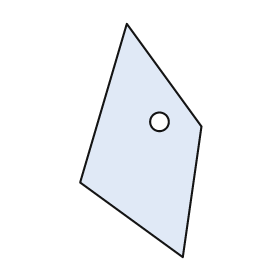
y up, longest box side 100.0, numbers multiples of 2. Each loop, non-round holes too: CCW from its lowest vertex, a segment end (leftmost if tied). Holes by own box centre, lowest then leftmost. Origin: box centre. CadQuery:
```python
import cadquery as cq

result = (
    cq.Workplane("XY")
    .moveTo(18.0, -50.0)
    .lineTo(26.0, 6.0)
    .lineTo(-6.0, 50.0)
    .lineTo(-26.0, -18.0)
    .close()
    .moveTo(8.0, 8.0)
    .circle(4.0)
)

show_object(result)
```